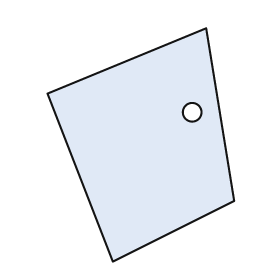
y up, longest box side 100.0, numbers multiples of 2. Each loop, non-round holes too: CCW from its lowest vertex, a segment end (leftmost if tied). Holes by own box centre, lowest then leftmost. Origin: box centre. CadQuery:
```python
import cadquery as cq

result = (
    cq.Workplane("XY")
    .moveTo(-12.0, -50.0)
    .lineTo(40.0, -24.0)
    .lineTo(28.0, 50.0)
    .lineTo(-40.0, 22.0)
    .close()
    .moveTo(22.0, 14.0)
    .circle(4.0)
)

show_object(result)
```